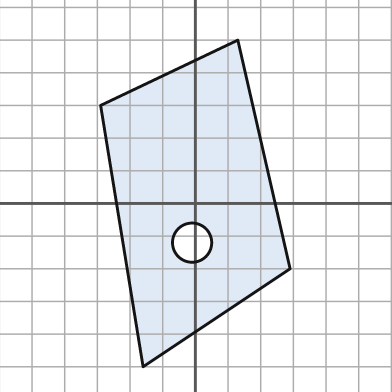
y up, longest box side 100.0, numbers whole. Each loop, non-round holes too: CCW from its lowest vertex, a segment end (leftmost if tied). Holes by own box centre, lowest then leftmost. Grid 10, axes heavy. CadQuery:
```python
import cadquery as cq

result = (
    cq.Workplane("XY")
    .moveTo(-16.0, -50.0)
    .lineTo(29.0, -20.0)
    .lineTo(13.0, 50.0)
    .lineTo(-29.0, 30.0)
    .close()
    .moveTo(-1.0, -12.0)
    .circle(6.0)
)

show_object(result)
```